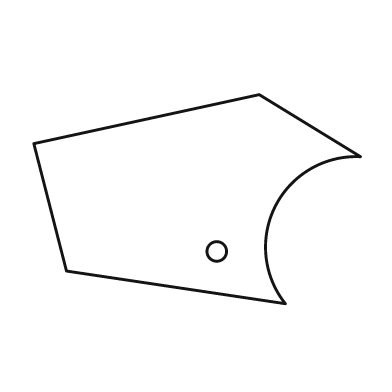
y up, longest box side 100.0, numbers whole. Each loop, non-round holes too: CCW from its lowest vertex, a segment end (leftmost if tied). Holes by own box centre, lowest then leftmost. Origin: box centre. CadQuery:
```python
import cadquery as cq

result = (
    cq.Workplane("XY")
    .moveTo(27.0, -32.0)
    .threePointArc((24.0, -2.0), (50.0, 13.0))
    .lineTo(19.0, 32.0)
    .lineTo(-50.0, 17.0)
    .lineTo(-40.0, -22.0)
    .close()
    .moveTo(6.0, -16.0)
    .circle(3.0)
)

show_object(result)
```